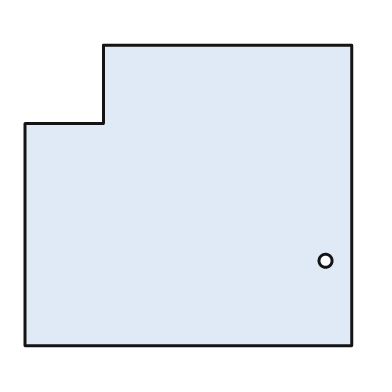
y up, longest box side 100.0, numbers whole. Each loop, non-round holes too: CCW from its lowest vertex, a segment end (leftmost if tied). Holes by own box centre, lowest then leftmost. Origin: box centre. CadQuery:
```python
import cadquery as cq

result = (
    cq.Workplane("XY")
    .moveTo(-50.0, -46.0)
    .lineTo(50.0, -46.0)
    .lineTo(50.0, 46.0)
    .lineTo(-26.0, 46.0)
    .lineTo(-26.0, 22.0)
    .lineTo(-50.0, 22.0)
    .close()
    .moveTo(42.0, -20.0)
    .circle(2.0)
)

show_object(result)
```